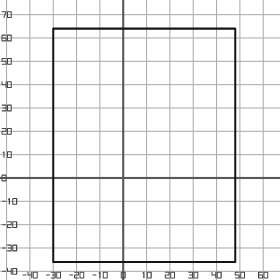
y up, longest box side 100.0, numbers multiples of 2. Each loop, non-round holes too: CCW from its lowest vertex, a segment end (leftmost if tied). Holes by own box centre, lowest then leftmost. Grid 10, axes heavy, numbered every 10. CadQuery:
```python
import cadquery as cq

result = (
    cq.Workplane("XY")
    .moveTo(-30.0, -36.0)
    .lineTo(48.0, -36.0)
    .lineTo(48.0, 64.0)
    .lineTo(-30.0, 64.0)
    .close()
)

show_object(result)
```